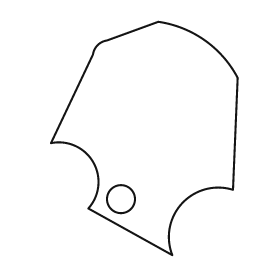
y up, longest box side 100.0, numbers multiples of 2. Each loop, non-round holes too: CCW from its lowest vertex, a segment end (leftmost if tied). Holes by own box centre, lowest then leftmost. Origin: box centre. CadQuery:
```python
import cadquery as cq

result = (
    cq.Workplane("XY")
    .moveTo(12.0, -50.0)
    .threePointArc((16.0, -28.0), (38.0, -22.0))
    .lineTo(40.0, 26.0)
    .threePointArc((26.0, 42.0), (6.0, 50.0))
    .lineTo(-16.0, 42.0)
    .threePointArc((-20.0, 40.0), (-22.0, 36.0))
    .lineTo(-40.0, -2.0)
    .threePointArc((-22.0, -10.0), (-24.0, -30.0))
    .close()
    .moveTo(-10.0, -26.0)
    .circle(6.0)
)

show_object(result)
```